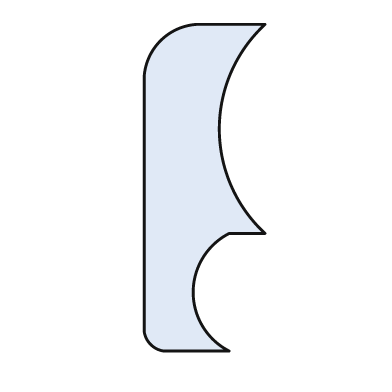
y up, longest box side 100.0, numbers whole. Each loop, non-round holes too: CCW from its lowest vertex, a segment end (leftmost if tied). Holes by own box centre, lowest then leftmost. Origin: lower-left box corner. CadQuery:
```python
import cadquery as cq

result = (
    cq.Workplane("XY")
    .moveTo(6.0, 0.0)
    .lineTo(26.0, 0.0)
    .threePointArc((15.0, 18.0), (26.0, 36.0))
    .lineTo(37.0, 36.0)
    .threePointArc((23.0, 68.0), (37.0, 100.0))
    .lineTo(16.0, 100.0)
    .threePointArc((5.0, 95.0), (0.0, 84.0))
    .lineTo(0.0, 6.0)
    .threePointArc((2.0, 2.0), (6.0, 0.0))
    .close()
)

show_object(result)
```